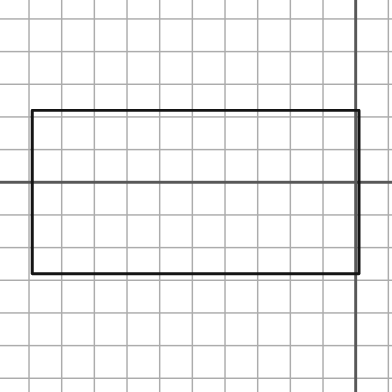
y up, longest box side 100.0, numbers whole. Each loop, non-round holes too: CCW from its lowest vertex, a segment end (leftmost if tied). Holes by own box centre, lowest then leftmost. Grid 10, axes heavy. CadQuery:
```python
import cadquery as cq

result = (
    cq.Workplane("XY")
    .moveTo(-99.0, -28.0)
    .lineTo(1.0, -28.0)
    .lineTo(1.0, 22.0)
    .lineTo(-99.0, 22.0)
    .close()
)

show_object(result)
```